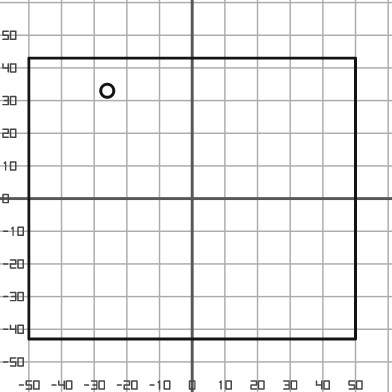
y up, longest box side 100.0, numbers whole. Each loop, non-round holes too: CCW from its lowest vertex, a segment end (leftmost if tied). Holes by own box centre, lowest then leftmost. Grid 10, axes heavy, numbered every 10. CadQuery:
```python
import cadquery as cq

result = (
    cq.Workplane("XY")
    .moveTo(-50.0, -43.0)
    .lineTo(50.0, -43.0)
    .lineTo(50.0, 43.0)
    .lineTo(-50.0, 43.0)
    .close()
    .moveTo(-26.0, 33.0)
    .circle(2.0)
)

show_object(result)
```